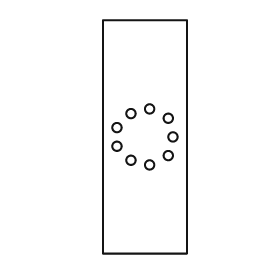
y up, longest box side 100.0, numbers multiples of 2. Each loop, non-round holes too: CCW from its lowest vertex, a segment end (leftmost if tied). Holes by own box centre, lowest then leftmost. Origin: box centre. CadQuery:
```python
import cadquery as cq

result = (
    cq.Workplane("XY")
    .moveTo(-18.0, -50.0)
    .lineTo(18.0, -50.0)
    .lineTo(18.0, 50.0)
    .lineTo(-18.0, 50.0)
    .close()
    .moveTo(2.0, -12.0)
    .circle(2.0)
    .moveTo(-6.0, -10.0)
    .circle(2.0)
    .moveTo(10.0, -8.0)
    .circle(2.0)
    .moveTo(-12.0, -4.0)
    .circle(2.0)
    .moveTo(12.0, 0.0)
    .circle(2.0)
    .moveTo(-12.0, 4.0)
    .circle(2.0)
    .moveTo(10.0, 8.0)
    .circle(2.0)
    .moveTo(-6.0, 10.0)
    .circle(2.0)
    .moveTo(2.0, 12.0)
    .circle(2.0)
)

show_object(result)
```